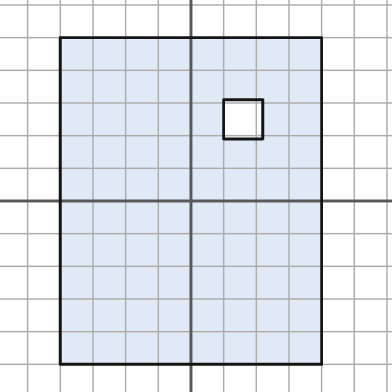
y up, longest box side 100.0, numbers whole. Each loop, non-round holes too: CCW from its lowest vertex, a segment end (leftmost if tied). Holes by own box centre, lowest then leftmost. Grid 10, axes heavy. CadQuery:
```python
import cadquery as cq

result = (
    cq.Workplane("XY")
    .moveTo(-40.0, -50.0)
    .lineTo(40.0, -50.0)
    .lineTo(40.0, 50.0)
    .lineTo(-40.0, 50.0)
    .close()
    .moveTo(10.0, 19.0)
    .lineTo(22.0, 19.0)
    .lineTo(22.0, 31.0)
    .lineTo(10.0, 31.0)
    .close()
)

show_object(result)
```